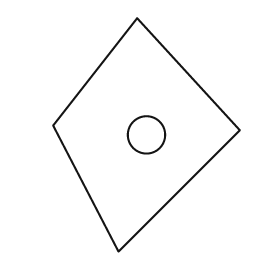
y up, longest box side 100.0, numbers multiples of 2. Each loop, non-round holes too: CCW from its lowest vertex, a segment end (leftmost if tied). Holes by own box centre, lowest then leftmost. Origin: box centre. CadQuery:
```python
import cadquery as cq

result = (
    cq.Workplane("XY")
    .moveTo(-12.0, -50.0)
    .lineTo(40.0, 2.0)
    .lineTo(-4.0, 50.0)
    .lineTo(-40.0, 4.0)
    .close()
    .moveTo(0.0, 0.0)
    .circle(8.0)
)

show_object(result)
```